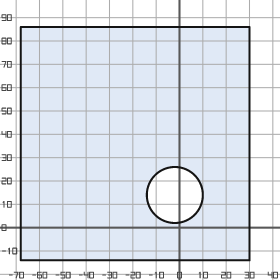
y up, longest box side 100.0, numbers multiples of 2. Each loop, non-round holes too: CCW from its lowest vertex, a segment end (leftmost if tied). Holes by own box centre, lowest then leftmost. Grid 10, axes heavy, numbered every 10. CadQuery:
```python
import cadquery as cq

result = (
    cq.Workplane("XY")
    .moveTo(-68.0, -14.0)
    .lineTo(30.0, -14.0)
    .lineTo(30.0, 86.0)
    .lineTo(-68.0, 86.0)
    .close()
    .moveTo(-2.0, 14.0)
    .circle(12.0)
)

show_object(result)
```